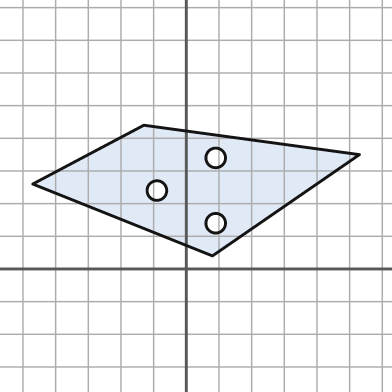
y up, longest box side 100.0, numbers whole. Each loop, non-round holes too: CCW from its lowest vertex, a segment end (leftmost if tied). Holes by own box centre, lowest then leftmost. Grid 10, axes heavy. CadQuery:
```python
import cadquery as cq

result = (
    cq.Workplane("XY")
    .moveTo(8.0, 4.0)
    .lineTo(53.0, 35.0)
    .lineTo(-13.0, 44.0)
    .lineTo(-47.0, 26.0)
    .close()
    .moveTo(9.0, 14.0)
    .circle(3.0)
    .moveTo(-9.0, 24.0)
    .circle(3.0)
    .moveTo(9.0, 34.0)
    .circle(3.0)
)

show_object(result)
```